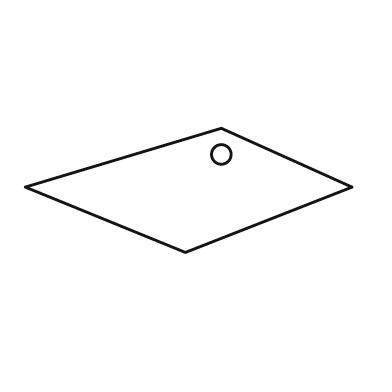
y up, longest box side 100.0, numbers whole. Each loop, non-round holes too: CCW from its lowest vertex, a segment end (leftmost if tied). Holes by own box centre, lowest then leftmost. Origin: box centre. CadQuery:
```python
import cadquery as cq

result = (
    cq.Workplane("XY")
    .moveTo(-1.0, -19.0)
    .lineTo(50.0, 1.0)
    .lineTo(10.0, 19.0)
    .lineTo(-50.0, 1.0)
    .close()
    .moveTo(10.0, 11.0)
    .circle(3.0)
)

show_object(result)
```